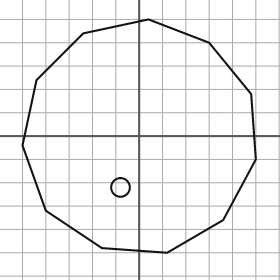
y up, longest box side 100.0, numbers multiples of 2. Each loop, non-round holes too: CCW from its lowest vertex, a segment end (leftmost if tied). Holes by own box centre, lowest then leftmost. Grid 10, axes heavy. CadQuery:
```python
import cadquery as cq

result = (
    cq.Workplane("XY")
    .moveTo(12.0, -50.0)
    .lineTo(36.0, -36.0)
    .lineTo(50.0, -10.0)
    .lineTo(48.0, 18.0)
    .lineTo(30.0, 40.0)
    .lineTo(4.0, 50.0)
    .lineTo(-24.0, 44.0)
    .lineTo(-44.0, 24.0)
    .lineTo(-50.0, -4.0)
    .lineTo(-40.0, -32.0)
    .lineTo(-16.0, -48.0)
    .close()
    .moveTo(-8.0, -22.0)
    .circle(4.0)
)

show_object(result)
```